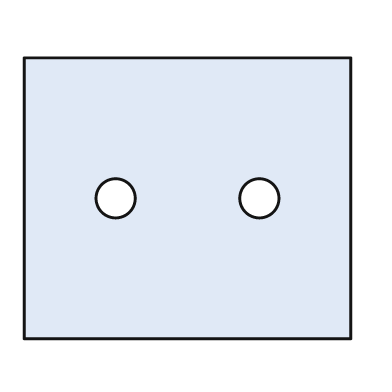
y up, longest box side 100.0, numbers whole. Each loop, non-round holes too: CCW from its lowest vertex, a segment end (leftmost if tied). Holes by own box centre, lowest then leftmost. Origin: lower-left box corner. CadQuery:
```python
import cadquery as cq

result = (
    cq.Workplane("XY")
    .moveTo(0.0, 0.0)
    .lineTo(100.0, 0.0)
    .lineTo(100.0, 86.0)
    .lineTo(0.0, 86.0)
    .close()
    .moveTo(28.0, 43.0)
    .circle(6.0)
    .moveTo(72.0, 43.0)
    .circle(6.0)
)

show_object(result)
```